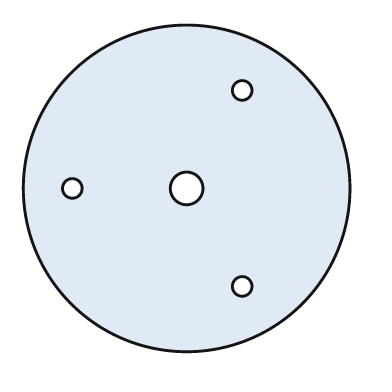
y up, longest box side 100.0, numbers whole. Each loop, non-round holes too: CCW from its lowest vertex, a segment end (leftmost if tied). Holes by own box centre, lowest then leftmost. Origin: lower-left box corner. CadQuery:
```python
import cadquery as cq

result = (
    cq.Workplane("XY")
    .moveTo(50.0, 50.0)
    .circle(50.0)
    .moveTo(67.0, 20.0)
    .circle(3.0)
    .moveTo(15.0, 50.0)
    .circle(3.0)
    .moveTo(50.0, 50.0)
    .circle(5.0)
    .moveTo(67.0, 80.0)
    .circle(3.0)
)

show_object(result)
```